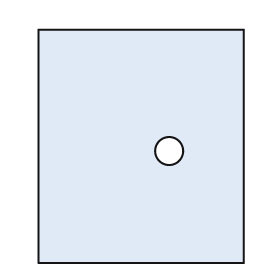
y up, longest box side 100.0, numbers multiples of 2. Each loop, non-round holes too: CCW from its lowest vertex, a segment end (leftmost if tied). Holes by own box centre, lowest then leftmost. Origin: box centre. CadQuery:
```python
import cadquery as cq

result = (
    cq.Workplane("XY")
    .moveTo(-44.0, -50.0)
    .lineTo(44.0, -50.0)
    .lineTo(44.0, 50.0)
    .lineTo(-44.0, 50.0)
    .close()
    .moveTo(12.0, -2.0)
    .circle(6.0)
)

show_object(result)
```